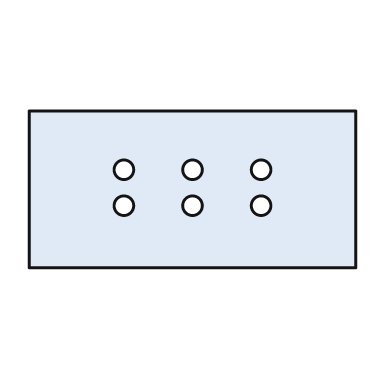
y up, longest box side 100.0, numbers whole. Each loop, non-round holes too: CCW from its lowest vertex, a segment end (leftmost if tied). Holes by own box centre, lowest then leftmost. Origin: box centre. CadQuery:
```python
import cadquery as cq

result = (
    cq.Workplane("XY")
    .moveTo(-50.0, -24.0)
    .lineTo(50.0, -24.0)
    .lineTo(50.0, 24.0)
    .lineTo(-50.0, 24.0)
    .close()
    .moveTo(-21.0, -5.0)
    .circle(3.0)
    .moveTo(0.0, -5.0)
    .circle(3.0)
    .moveTo(21.0, -5.0)
    .circle(3.0)
    .moveTo(-21.0, 6.0)
    .circle(3.0)
    .moveTo(0.0, 6.0)
    .circle(3.0)
    .moveTo(21.0, 6.0)
    .circle(3.0)
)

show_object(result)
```